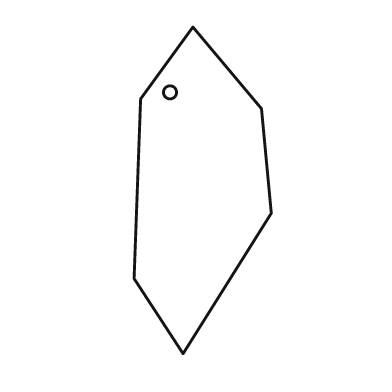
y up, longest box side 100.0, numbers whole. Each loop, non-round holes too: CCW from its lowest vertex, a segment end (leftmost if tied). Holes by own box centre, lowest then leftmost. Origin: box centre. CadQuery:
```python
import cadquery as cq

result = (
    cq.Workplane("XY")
    .moveTo(-6.0, -50.0)
    .lineTo(21.0, -7.0)
    .lineTo(18.0, 25.0)
    .lineTo(-3.0, 50.0)
    .lineTo(-19.0, 28.0)
    .lineTo(-21.0, -27.0)
    .close()
    .moveTo(-10.0, 30.0)
    .circle(2.0)
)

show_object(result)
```